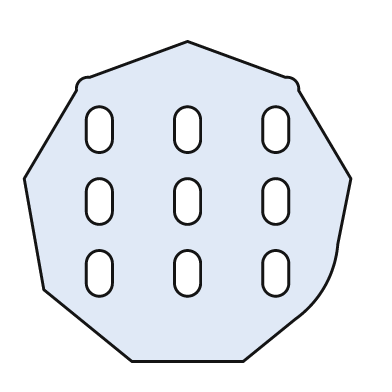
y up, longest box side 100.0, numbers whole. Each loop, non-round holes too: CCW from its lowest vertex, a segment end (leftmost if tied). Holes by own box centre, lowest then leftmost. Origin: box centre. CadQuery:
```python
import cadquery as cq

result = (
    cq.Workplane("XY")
    .moveTo(-17.0, -49.0)
    .lineTo(17.0, -49.0)
    .lineTo(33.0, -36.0)
    .threePointArc((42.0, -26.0), (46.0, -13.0))
    .lineTo(50.0, 7.0)
    .lineTo(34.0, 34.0)
    .threePointArc((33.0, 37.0), (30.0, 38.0))
    .lineTo(0.0, 49.0)
    .lineTo(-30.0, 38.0)
    .threePointArc((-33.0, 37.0), (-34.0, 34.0))
    .lineTo(-50.0, 7.0)
    .lineTo(-44.0, -27.0)
    .close()
    .moveTo(-31.0, -25.0)
    .threePointArc((-27.0, -29.0), (-23.0, -25.0))
    .lineTo(-23.0, -19.0)
    .threePointArc((-27.0, -15.0), (-31.0, -19.0))
    .close()
    .moveTo(-4.0, -25.0)
    .threePointArc((0.0, -29.0), (4.0, -25.0))
    .lineTo(4.0, -19.0)
    .threePointArc((0.0, -15.0), (-4.0, -19.0))
    .close()
    .moveTo(23.0, -25.0)
    .threePointArc((27.0, -29.0), (31.0, -25.0))
    .lineTo(31.0, -19.0)
    .threePointArc((27.0, -15.0), (23.0, -19.0))
    .close()
    .moveTo(-31.0, -3.0)
    .threePointArc((-27.0, -7.0), (-23.0, -3.0))
    .lineTo(-23.0, 3.0)
    .threePointArc((-27.0, 7.0), (-31.0, 3.0))
    .close()
    .moveTo(-4.0, -3.0)
    .threePointArc((0.0, -7.0), (4.0, -3.0))
    .lineTo(4.0, 3.0)
    .threePointArc((0.0, 7.0), (-4.0, 3.0))
    .close()
    .moveTo(23.0, -3.0)
    .threePointArc((27.0, -7.0), (31.0, -3.0))
    .lineTo(31.0, 3.0)
    .threePointArc((27.0, 7.0), (23.0, 3.0))
    .close()
    .moveTo(-31.0, 19.0)
    .threePointArc((-27.0, 15.0), (-23.0, 19.0))
    .lineTo(-23.0, 25.0)
    .threePointArc((-27.0, 29.0), (-31.0, 25.0))
    .close()
    .moveTo(-4.0, 19.0)
    .threePointArc((0.0, 15.0), (4.0, 19.0))
    .lineTo(4.0, 25.0)
    .threePointArc((0.0, 29.0), (-4.0, 25.0))
    .close()
    .moveTo(23.0, 19.0)
    .threePointArc((27.0, 15.0), (31.0, 19.0))
    .lineTo(31.0, 25.0)
    .threePointArc((27.0, 29.0), (23.0, 25.0))
    .close()
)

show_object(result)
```